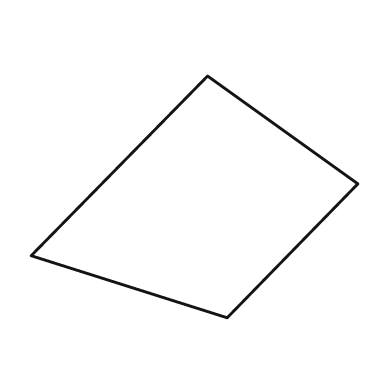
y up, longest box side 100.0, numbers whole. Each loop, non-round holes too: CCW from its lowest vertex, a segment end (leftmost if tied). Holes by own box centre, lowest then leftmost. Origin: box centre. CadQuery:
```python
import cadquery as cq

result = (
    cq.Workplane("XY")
    .moveTo(10.0, -37.0)
    .lineTo(50.0, 4.0)
    .lineTo(4.0, 37.0)
    .lineTo(-50.0, -18.0)
    .close()
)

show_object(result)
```